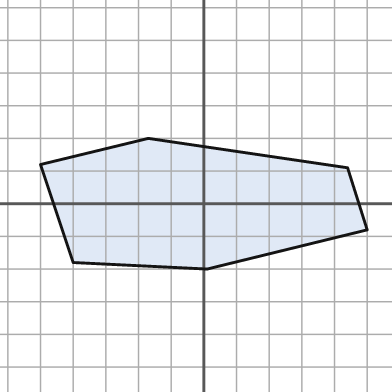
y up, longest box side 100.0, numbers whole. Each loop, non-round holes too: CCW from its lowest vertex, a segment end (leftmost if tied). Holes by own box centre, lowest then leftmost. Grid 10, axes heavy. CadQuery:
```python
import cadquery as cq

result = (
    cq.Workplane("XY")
    .moveTo(1.0, -20.0)
    .lineTo(50.0, -8.0)
    .lineTo(44.0, 11.0)
    .lineTo(-17.0, 20.0)
    .lineTo(-50.0, 12.0)
    .lineTo(-40.0, -18.0)
    .close()
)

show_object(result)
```